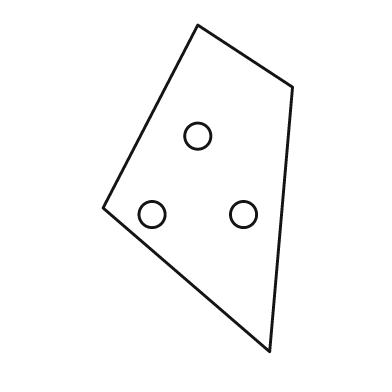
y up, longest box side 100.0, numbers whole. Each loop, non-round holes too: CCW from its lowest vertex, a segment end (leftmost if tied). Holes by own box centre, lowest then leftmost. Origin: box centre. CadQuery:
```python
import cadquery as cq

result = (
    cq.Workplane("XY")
    .moveTo(22.0, -50.0)
    .lineTo(29.0, 31.0)
    .lineTo(0.0, 50.0)
    .lineTo(-29.0, -6.0)
    .close()
    .moveTo(-14.0, -8.0)
    .circle(4.0)
    .moveTo(14.0, -8.0)
    .circle(4.0)
    .moveTo(0.0, 16.0)
    .circle(4.0)
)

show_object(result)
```